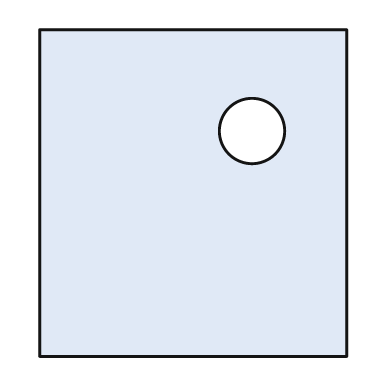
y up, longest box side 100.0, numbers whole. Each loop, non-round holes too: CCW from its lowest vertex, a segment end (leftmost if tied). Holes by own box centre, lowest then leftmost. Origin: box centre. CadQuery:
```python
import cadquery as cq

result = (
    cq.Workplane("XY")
    .moveTo(-47.0, -50.0)
    .lineTo(47.0, -50.0)
    .lineTo(47.0, 50.0)
    .lineTo(-47.0, 50.0)
    .close()
    .moveTo(18.0, 19.0)
    .circle(10.0)
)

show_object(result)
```